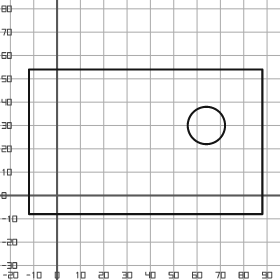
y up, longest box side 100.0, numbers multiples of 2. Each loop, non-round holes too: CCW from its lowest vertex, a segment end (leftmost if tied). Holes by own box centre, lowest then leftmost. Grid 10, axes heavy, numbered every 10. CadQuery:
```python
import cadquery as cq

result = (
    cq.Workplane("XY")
    .moveTo(-12.0, -8.0)
    .lineTo(88.0, -8.0)
    .lineTo(88.0, 54.0)
    .lineTo(-12.0, 54.0)
    .close()
    .moveTo(64.0, 30.0)
    .circle(8.0)
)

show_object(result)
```